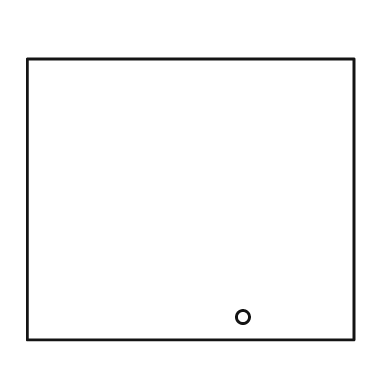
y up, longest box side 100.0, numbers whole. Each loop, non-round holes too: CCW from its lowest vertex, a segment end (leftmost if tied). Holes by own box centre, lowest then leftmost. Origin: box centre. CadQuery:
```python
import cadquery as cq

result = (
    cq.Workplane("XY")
    .moveTo(-50.0, -43.0)
    .lineTo(50.0, -43.0)
    .lineTo(50.0, 43.0)
    .lineTo(-50.0, 43.0)
    .close()
    .moveTo(16.0, -36.0)
    .circle(2.0)
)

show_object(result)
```